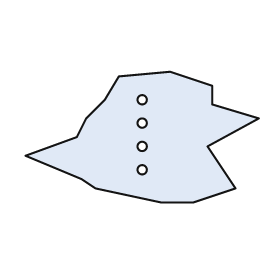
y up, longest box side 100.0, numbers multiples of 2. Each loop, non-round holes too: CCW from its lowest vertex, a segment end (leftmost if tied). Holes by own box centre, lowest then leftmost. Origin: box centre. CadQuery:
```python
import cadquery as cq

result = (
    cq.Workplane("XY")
    .moveTo(8.0, -28.0)
    .lineTo(22.0, -28.0)
    .lineTo(40.0, -22.0)
    .lineTo(28.0, -4.0)
    .lineTo(50.0, 8.0)
    .lineTo(30.0, 14.0)
    .lineTo(30.0, 22.0)
    .lineTo(12.0, 28.0)
    .lineTo(-10.0, 26.0)
    .lineTo(-16.0, 16.0)
    .lineTo(-24.0, 8.0)
    .lineTo(-28.0, 0.0)
    .lineTo(-50.0, -8.0)
    .lineTo(-26.0, -18.0)
    .lineTo(-20.0, -22.0)
    .close()
    .moveTo(0.0, -14.0)
    .circle(2.0)
    .moveTo(0.0, -4.0)
    .circle(2.0)
    .moveTo(0.0, 6.0)
    .circle(2.0)
    .moveTo(0.0, 16.0)
    .circle(2.0)
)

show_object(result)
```